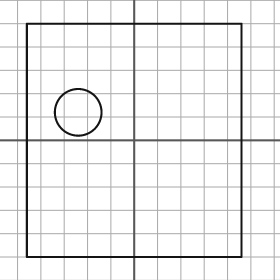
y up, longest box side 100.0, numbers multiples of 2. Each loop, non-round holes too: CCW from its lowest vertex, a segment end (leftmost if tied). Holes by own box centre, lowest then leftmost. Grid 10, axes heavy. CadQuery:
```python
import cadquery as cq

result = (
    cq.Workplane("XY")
    .moveTo(-46.0, -50.0)
    .lineTo(46.0, -50.0)
    .lineTo(46.0, 50.0)
    .lineTo(-46.0, 50.0)
    .close()
    .moveTo(-24.0, 12.0)
    .circle(10.0)
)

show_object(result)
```